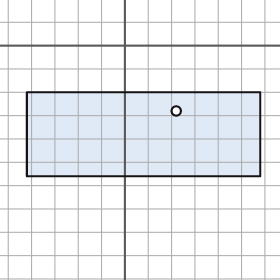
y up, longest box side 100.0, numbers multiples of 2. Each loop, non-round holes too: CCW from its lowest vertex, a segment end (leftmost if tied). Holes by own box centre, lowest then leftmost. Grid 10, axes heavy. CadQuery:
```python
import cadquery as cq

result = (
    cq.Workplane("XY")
    .moveTo(-42.0, -56.0)
    .lineTo(58.0, -56.0)
    .lineTo(58.0, -20.0)
    .lineTo(-42.0, -20.0)
    .close()
    .moveTo(22.0, -28.0)
    .circle(2.0)
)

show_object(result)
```